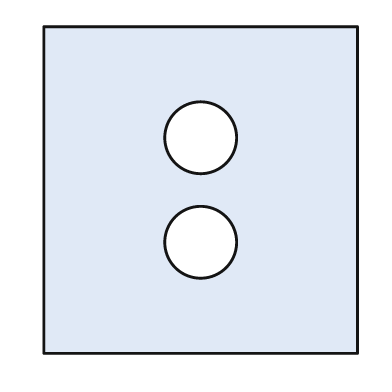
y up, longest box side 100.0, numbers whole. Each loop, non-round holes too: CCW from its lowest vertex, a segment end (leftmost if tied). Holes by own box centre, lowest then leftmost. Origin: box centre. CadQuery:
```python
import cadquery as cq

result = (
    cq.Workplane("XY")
    .moveTo(-48.0, -50.0)
    .lineTo(48.0, -50.0)
    .lineTo(48.0, 50.0)
    .lineTo(-48.0, 50.0)
    .close()
    .moveTo(0.0, -16.0)
    .circle(11.0)
    .moveTo(0.0, 16.0)
    .circle(11.0)
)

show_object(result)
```